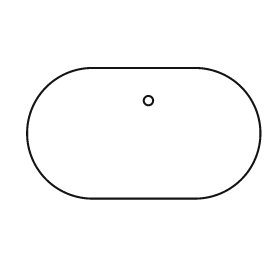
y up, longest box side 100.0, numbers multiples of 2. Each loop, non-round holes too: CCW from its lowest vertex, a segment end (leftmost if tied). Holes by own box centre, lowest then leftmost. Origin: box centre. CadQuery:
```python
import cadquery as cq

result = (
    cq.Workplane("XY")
    .moveTo(-22.0, -28.0)
    .lineTo(22.0, -28.0)
    .threePointArc((50.0, 0.0), (22.0, 28.0))
    .lineTo(-22.0, 28.0)
    .threePointArc((-50.0, 0.0), (-22.0, -28.0))
    .close()
    .moveTo(2.0, 14.0)
    .circle(2.0)
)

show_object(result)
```